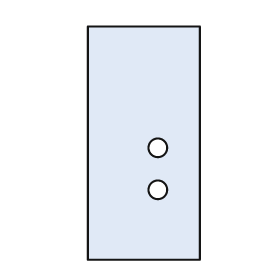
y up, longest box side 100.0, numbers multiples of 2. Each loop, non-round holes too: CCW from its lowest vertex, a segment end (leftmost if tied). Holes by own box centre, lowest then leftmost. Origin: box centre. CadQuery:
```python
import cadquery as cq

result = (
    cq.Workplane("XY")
    .moveTo(-24.0, -50.0)
    .lineTo(24.0, -50.0)
    .lineTo(24.0, 50.0)
    .lineTo(-24.0, 50.0)
    .close()
    .moveTo(6.0, -20.0)
    .circle(4.0)
    .moveTo(6.0, -2.0)
    .circle(4.0)
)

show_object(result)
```